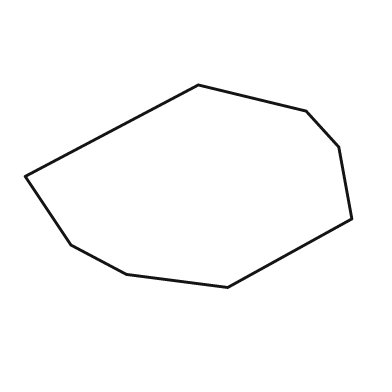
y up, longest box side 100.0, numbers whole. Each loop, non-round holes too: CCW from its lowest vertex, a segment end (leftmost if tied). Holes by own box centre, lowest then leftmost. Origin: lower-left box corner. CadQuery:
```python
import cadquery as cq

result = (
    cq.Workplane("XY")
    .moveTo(62.0, 0.0)
    .lineTo(100.0, 21.0)
    .lineTo(96.0, 43.0)
    .lineTo(86.0, 54.0)
    .lineTo(53.0, 62.0)
    .lineTo(0.0, 34.0)
    .lineTo(14.0, 13.0)
    .lineTo(31.0, 4.0)
    .close()
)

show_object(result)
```